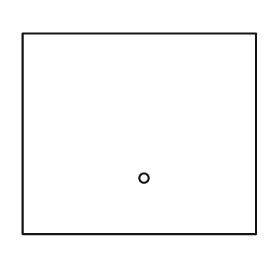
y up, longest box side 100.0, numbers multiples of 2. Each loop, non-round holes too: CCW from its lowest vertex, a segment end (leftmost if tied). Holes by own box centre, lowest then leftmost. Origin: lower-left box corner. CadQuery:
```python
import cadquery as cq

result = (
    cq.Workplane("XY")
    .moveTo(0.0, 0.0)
    .lineTo(100.0, 0.0)
    .lineTo(100.0, 86.0)
    .lineTo(0.0, 86.0)
    .close()
    .moveTo(52.0, 24.0)
    .circle(2.0)
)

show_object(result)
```